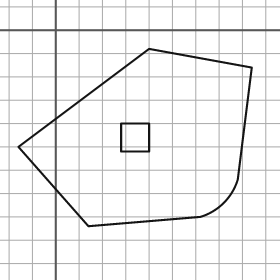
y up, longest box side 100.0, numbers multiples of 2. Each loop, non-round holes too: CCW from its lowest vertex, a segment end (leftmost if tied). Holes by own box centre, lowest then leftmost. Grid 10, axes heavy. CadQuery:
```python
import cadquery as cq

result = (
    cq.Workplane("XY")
    .moveTo(14.0, -84.0)
    .lineTo(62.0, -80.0)
    .threePointArc((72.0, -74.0), (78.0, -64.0))
    .lineTo(84.0, -16.0)
    .lineTo(40.0, -8.0)
    .lineTo(-16.0, -50.0)
    .close()
    .moveTo(28.0, -52.0)
    .lineTo(40.0, -52.0)
    .lineTo(40.0, -40.0)
    .lineTo(28.0, -40.0)
    .close()
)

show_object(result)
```